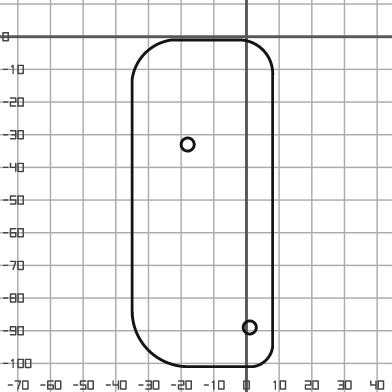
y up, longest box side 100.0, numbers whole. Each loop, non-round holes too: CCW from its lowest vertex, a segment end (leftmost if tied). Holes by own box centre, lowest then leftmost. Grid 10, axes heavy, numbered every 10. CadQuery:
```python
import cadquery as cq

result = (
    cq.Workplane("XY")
    .moveTo(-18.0, -101.0)
    .lineTo(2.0, -101.0)
    .threePointArc((6.0, -99.0), (8.0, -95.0))
    .lineTo(8.0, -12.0)
    .threePointArc((5.0, -4.0), (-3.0, -1.0))
    .lineTo(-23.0, -1.0)
    .threePointArc((-31.0, -5.0), (-35.0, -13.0))
    .lineTo(-35.0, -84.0)
    .threePointArc((-30.0, -96.0), (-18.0, -101.0))
    .close()
    .moveTo(1.0, -89.0)
    .circle(2.0)
    .moveTo(-18.0, -33.0)
    .circle(2.0)
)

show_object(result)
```